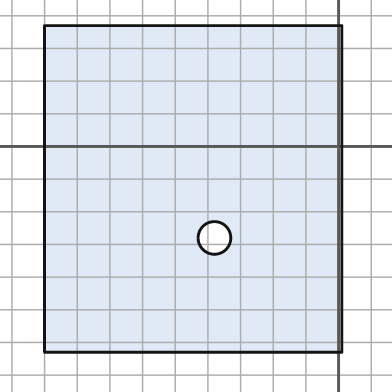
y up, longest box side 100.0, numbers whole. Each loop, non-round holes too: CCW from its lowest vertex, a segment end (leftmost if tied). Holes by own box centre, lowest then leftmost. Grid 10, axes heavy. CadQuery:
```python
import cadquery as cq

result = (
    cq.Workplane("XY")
    .moveTo(-90.0, -63.0)
    .lineTo(1.0, -63.0)
    .lineTo(1.0, 37.0)
    .lineTo(-90.0, 37.0)
    .close()
    .moveTo(-38.0, -28.0)
    .circle(5.0)
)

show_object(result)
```